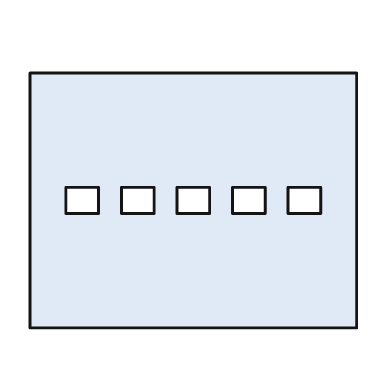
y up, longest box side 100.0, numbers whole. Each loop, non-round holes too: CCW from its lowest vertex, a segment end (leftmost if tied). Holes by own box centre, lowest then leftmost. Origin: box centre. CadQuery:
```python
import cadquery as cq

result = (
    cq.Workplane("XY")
    .moveTo(-50.0, -39.0)
    .lineTo(50.0, -39.0)
    .lineTo(50.0, 39.0)
    .lineTo(-50.0, 39.0)
    .close()
    .moveTo(-39.0, -4.0)
    .lineTo(-29.0, -4.0)
    .lineTo(-29.0, 4.0)
    .lineTo(-39.0, 4.0)
    .close()
    .moveTo(-22.0, -4.0)
    .lineTo(-12.0, -4.0)
    .lineTo(-12.0, 4.0)
    .lineTo(-22.0, 4.0)
    .close()
    .moveTo(-5.0, -4.0)
    .lineTo(5.0, -4.0)
    .lineTo(5.0, 4.0)
    .lineTo(-5.0, 4.0)
    .close()
    .moveTo(12.0, -4.0)
    .lineTo(22.0, -4.0)
    .lineTo(22.0, 4.0)
    .lineTo(12.0, 4.0)
    .close()
    .moveTo(29.0, -4.0)
    .lineTo(39.0, -4.0)
    .lineTo(39.0, 4.0)
    .lineTo(29.0, 4.0)
    .close()
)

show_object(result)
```